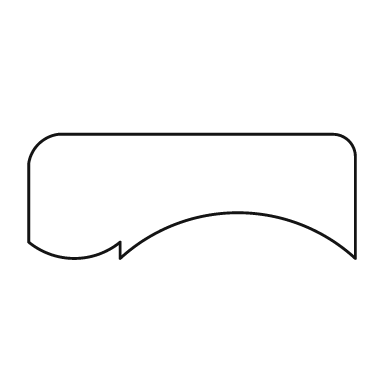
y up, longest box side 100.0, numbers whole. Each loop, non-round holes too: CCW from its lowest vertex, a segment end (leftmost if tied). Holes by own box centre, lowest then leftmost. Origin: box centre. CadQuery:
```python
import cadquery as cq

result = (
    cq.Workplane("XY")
    .moveTo(-22.0, -19.0)
    .threePointArc((14.0, -5.0), (50.0, -19.0))
    .lineTo(50.0, 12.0)
    .threePointArc((48.0, 17.0), (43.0, 19.0))
    .lineTo(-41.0, 19.0)
    .threePointArc((-47.0, 16.0), (-50.0, 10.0))
    .lineTo(-50.0, -14.0)
    .threePointArc((-36.0, -19.0), (-22.0, -14.0))
    .close()
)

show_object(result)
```